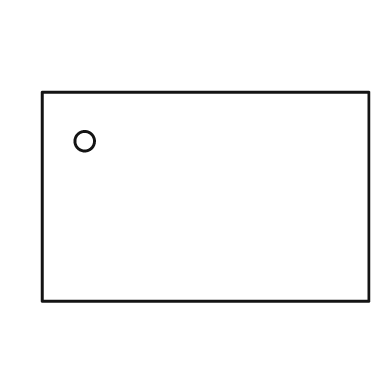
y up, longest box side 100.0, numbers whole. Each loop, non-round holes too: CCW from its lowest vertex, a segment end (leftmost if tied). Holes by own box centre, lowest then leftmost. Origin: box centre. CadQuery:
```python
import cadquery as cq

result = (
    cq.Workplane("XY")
    .moveTo(-50.0, -32.0)
    .lineTo(50.0, -32.0)
    .lineTo(50.0, 32.0)
    .lineTo(-50.0, 32.0)
    .close()
    .moveTo(-37.0, 17.0)
    .circle(3.0)
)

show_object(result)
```